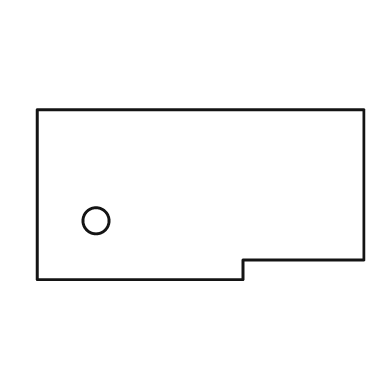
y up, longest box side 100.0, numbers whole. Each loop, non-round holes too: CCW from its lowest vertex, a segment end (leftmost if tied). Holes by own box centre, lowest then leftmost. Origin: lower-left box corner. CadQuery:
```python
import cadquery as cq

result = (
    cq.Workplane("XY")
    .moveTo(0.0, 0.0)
    .lineTo(63.0, 0.0)
    .lineTo(63.0, 6.0)
    .lineTo(100.0, 6.0)
    .lineTo(100.0, 52.0)
    .lineTo(0.0, 52.0)
    .close()
    .moveTo(18.0, 18.0)
    .circle(4.0)
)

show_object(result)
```